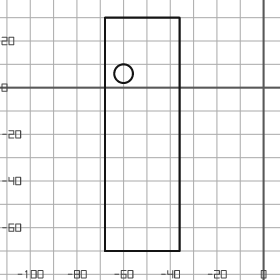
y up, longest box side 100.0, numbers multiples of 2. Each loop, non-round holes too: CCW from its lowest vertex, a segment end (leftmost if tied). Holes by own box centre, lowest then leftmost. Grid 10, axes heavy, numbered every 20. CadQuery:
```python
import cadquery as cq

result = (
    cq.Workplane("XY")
    .moveTo(-68.0, -70.0)
    .lineTo(-36.0, -70.0)
    .lineTo(-36.0, 30.0)
    .lineTo(-68.0, 30.0)
    .close()
    .moveTo(-60.0, 6.0)
    .circle(4.0)
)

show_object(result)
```